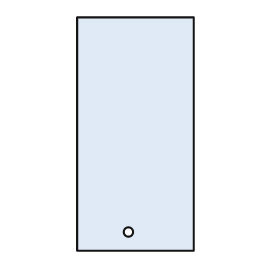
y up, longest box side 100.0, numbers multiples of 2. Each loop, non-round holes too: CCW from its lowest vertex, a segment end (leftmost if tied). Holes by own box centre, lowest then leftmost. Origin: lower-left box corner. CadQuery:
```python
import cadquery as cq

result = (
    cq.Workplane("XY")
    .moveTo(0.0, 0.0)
    .lineTo(50.0, 0.0)
    .lineTo(50.0, 100.0)
    .lineTo(0.0, 100.0)
    .close()
    .moveTo(22.0, 8.0)
    .circle(2.0)
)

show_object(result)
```